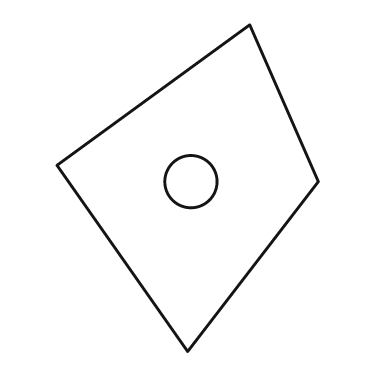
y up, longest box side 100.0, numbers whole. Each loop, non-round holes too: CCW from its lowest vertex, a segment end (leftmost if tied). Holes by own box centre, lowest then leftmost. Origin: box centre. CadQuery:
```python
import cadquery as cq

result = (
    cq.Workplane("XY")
    .moveTo(0.0, -50.0)
    .lineTo(40.0, 2.0)
    .lineTo(19.0, 50.0)
    .lineTo(-40.0, 7.0)
    .close()
    .moveTo(1.0, 2.0)
    .circle(8.0)
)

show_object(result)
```